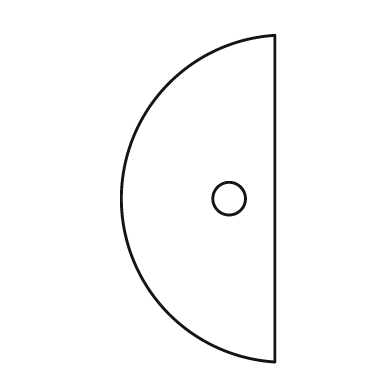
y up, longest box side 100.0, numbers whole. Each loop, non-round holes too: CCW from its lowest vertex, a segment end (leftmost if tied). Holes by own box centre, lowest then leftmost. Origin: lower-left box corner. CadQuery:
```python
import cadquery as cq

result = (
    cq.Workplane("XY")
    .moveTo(47.0, 0.0)
    .lineTo(47.0, 100.0)
    .threePointArc((0.0, 50.0), (47.0, 0.0))
    .close()
    .moveTo(33.0, 50.0)
    .circle(5.0)
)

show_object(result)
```